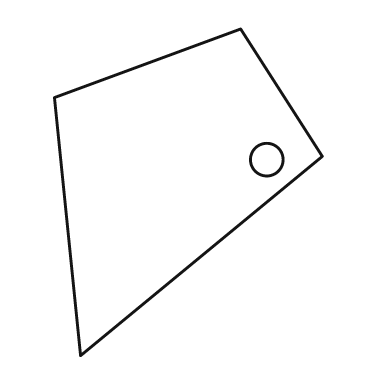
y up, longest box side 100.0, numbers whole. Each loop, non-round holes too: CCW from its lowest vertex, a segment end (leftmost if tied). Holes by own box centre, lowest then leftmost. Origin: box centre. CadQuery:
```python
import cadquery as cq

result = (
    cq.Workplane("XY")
    .moveTo(-33.0, -50.0)
    .lineTo(41.0, 11.0)
    .lineTo(16.0, 50.0)
    .lineTo(-41.0, 29.0)
    .close()
    .moveTo(24.0, 10.0)
    .circle(5.0)
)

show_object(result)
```